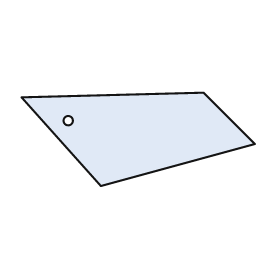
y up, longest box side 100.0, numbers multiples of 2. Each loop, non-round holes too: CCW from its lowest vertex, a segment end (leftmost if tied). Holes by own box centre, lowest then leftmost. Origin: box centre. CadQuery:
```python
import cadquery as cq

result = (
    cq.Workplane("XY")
    .moveTo(-16.0, -20.0)
    .lineTo(50.0, -2.0)
    .lineTo(28.0, 20.0)
    .lineTo(-50.0, 18.0)
    .close()
    .moveTo(-30.0, 8.0)
    .circle(2.0)
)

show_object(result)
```